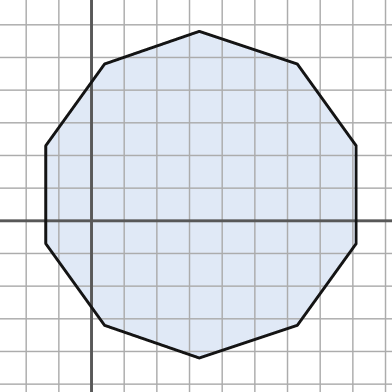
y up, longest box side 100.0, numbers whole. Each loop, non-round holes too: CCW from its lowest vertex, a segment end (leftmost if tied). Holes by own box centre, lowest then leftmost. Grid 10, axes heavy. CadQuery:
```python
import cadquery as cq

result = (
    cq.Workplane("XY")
    .moveTo(33.0, -42.0)
    .lineTo(63.0, -32.0)
    .lineTo(81.0, -7.0)
    .lineTo(81.0, 23.0)
    .lineTo(63.0, 48.0)
    .lineTo(33.0, 58.0)
    .lineTo(4.0, 48.0)
    .lineTo(-14.0, 23.0)
    .lineTo(-14.0, -7.0)
    .lineTo(4.0, -32.0)
    .close()
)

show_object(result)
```